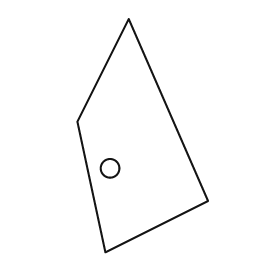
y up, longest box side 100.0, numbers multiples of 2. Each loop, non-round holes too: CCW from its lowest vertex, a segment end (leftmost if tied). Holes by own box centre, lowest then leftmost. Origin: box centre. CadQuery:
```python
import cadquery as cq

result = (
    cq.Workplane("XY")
    .moveTo(-16.0, -50.0)
    .lineTo(28.0, -28.0)
    .lineTo(-6.0, 50.0)
    .lineTo(-28.0, 6.0)
    .close()
    .moveTo(-14.0, -14.0)
    .circle(4.0)
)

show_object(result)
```